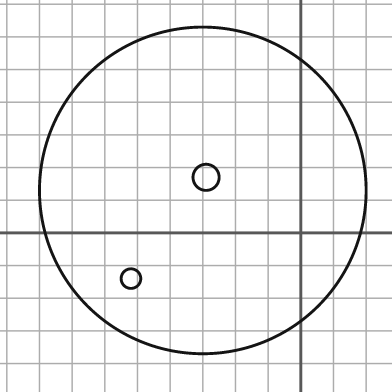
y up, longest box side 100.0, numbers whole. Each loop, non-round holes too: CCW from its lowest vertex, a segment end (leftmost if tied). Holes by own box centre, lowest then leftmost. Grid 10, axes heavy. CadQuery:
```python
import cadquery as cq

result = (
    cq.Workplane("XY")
    .moveTo(-30.0, 13.0)
    .circle(50.0)
    .moveTo(-52.0, -14.0)
    .circle(3.0)
    .moveTo(-29.0, 17.0)
    .circle(4.0)
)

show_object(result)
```